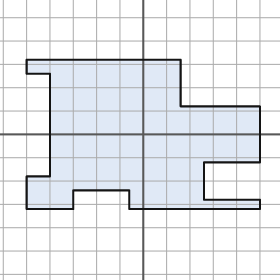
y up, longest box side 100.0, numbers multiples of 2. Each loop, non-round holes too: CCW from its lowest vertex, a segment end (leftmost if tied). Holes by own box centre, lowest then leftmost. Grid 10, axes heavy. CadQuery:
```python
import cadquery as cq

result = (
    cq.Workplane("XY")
    .moveTo(-50.0, -32.0)
    .lineTo(-30.0, -32.0)
    .lineTo(-30.0, -24.0)
    .lineTo(-6.0, -24.0)
    .lineTo(-6.0, -32.0)
    .lineTo(50.0, -32.0)
    .lineTo(50.0, -28.0)
    .lineTo(26.0, -28.0)
    .lineTo(26.0, -12.0)
    .lineTo(50.0, -12.0)
    .lineTo(50.0, 12.0)
    .lineTo(16.0, 12.0)
    .lineTo(16.0, 32.0)
    .lineTo(-50.0, 32.0)
    .lineTo(-50.0, 26.0)
    .lineTo(-40.0, 26.0)
    .lineTo(-40.0, -18.0)
    .lineTo(-50.0, -18.0)
    .close()
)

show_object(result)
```